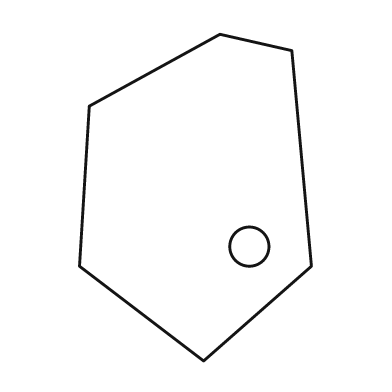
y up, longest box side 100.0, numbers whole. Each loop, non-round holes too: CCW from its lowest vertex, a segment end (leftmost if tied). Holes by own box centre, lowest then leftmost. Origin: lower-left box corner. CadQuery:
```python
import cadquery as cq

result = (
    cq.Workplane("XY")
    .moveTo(38.0, 0.0)
    .lineTo(71.0, 29.0)
    .lineTo(65.0, 95.0)
    .lineTo(43.0, 100.0)
    .lineTo(3.0, 78.0)
    .lineTo(0.0, 29.0)
    .close()
    .moveTo(52.0, 35.0)
    .circle(6.0)
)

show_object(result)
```